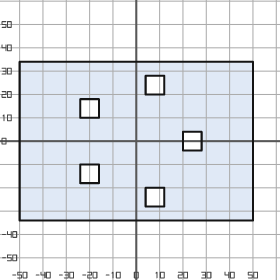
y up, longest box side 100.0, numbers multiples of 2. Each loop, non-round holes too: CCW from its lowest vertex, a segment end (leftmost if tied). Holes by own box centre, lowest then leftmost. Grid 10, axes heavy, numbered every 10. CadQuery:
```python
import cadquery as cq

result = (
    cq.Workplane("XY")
    .moveTo(-50.0, -34.0)
    .lineTo(50.0, -34.0)
    .lineTo(50.0, 34.0)
    .lineTo(-50.0, 34.0)
    .close()
    .moveTo(4.0, -28.0)
    .lineTo(12.0, -28.0)
    .lineTo(12.0, -20.0)
    .lineTo(4.0, -20.0)
    .close()
    .moveTo(-24.0, -18.0)
    .lineTo(-16.0, -18.0)
    .lineTo(-16.0, -10.0)
    .lineTo(-24.0, -10.0)
    .close()
    .moveTo(20.0, -4.0)
    .lineTo(28.0, -4.0)
    .lineTo(28.0, 4.0)
    .lineTo(20.0, 4.0)
    .close()
    .moveTo(-24.0, 10.0)
    .lineTo(-16.0, 10.0)
    .lineTo(-16.0, 18.0)
    .lineTo(-24.0, 18.0)
    .close()
    .moveTo(4.0, 20.0)
    .lineTo(12.0, 20.0)
    .lineTo(12.0, 28.0)
    .lineTo(4.0, 28.0)
    .close()
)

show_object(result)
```